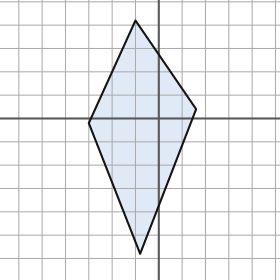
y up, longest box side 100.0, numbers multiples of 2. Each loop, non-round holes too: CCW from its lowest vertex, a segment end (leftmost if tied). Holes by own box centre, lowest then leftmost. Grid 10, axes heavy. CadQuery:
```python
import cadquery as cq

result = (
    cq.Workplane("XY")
    .moveTo(-8.0, -58.0)
    .lineTo(16.0, 4.0)
    .lineTo(-10.0, 42.0)
    .lineTo(-30.0, -2.0)
    .close()
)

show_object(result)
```